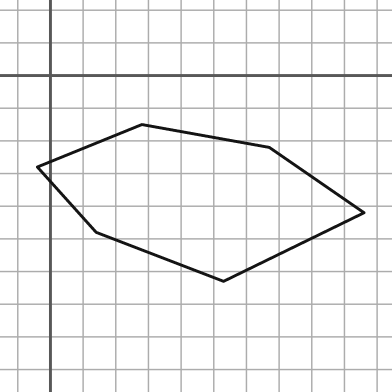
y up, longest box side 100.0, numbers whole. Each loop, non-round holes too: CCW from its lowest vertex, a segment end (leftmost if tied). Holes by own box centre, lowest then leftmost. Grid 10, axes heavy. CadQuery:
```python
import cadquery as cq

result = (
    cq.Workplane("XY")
    .moveTo(53.0, -63.0)
    .lineTo(96.0, -42.0)
    .lineTo(67.0, -22.0)
    .lineTo(28.0, -15.0)
    .lineTo(-4.0, -28.0)
    .lineTo(14.0, -48.0)
    .close()
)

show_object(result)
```